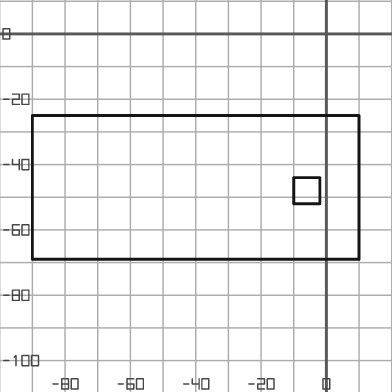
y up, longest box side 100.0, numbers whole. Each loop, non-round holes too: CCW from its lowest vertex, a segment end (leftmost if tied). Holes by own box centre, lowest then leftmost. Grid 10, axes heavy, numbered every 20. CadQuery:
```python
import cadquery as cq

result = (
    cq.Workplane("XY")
    .moveTo(-90.0, -69.0)
    .lineTo(10.0, -69.0)
    .lineTo(10.0, -25.0)
    .lineTo(-90.0, -25.0)
    .close()
    .moveTo(-10.0, -52.0)
    .lineTo(-2.0, -52.0)
    .lineTo(-2.0, -44.0)
    .lineTo(-10.0, -44.0)
    .close()
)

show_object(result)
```